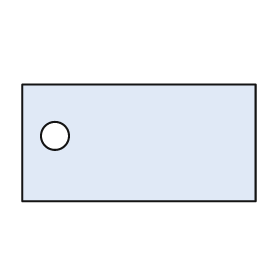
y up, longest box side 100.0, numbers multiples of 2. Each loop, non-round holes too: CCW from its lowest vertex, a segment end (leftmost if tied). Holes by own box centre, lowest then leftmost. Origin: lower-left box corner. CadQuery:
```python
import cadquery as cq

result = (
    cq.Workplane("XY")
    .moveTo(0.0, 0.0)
    .lineTo(100.0, 0.0)
    .lineTo(100.0, 50.0)
    .lineTo(0.0, 50.0)
    .close()
    .moveTo(14.0, 28.0)
    .circle(6.0)
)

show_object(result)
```